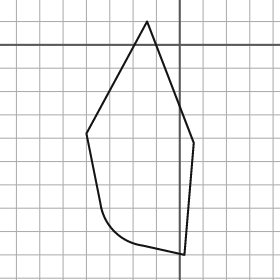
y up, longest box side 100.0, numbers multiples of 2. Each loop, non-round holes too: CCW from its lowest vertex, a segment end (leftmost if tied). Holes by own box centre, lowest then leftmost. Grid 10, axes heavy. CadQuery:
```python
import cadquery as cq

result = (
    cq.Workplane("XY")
    .moveTo(2.0, -90.0)
    .lineTo(6.0, -42.0)
    .lineTo(-14.0, 10.0)
    .lineTo(-40.0, -38.0)
    .lineTo(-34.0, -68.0)
    .threePointArc((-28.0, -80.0), (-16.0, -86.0))
    .close()
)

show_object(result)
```